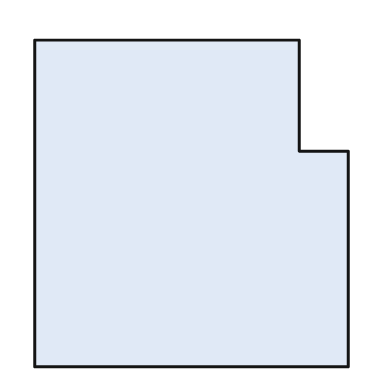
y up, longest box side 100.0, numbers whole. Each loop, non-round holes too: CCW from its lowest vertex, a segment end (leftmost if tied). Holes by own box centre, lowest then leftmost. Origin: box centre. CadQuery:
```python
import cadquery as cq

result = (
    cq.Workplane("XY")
    .moveTo(-48.0, -50.0)
    .lineTo(48.0, -50.0)
    .lineTo(48.0, 16.0)
    .lineTo(33.0, 16.0)
    .lineTo(33.0, 50.0)
    .lineTo(-48.0, 50.0)
    .close()
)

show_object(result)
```